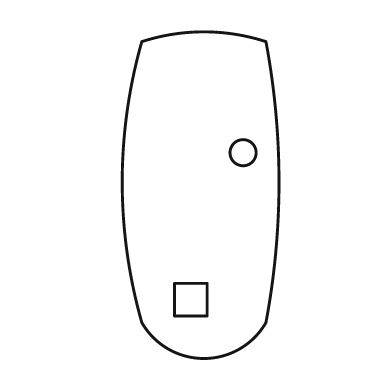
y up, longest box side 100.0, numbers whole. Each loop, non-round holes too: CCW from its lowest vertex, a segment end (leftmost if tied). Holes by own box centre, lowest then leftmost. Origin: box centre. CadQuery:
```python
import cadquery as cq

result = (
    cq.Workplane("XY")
    .moveTo(-18.0, -39.0)
    .threePointArc((1.0, -50.0), (20.0, -39.0))
    .threePointArc((24.0, 4.0), (20.0, 47.0))
    .threePointArc((1.0, 50.0), (-18.0, 47.0))
    .threePointArc((-24.0, 4.0), (-18.0, -39.0))
    .close()
    .moveTo(-8.0, -37.0)
    .lineTo(2.0, -37.0)
    .lineTo(2.0, -27.0)
    .lineTo(-8.0, -27.0)
    .close()
    .moveTo(13.0, 13.0)
    .circle(4.0)
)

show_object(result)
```